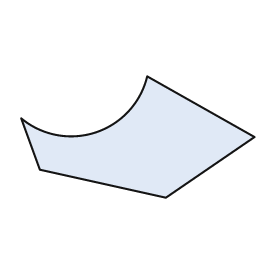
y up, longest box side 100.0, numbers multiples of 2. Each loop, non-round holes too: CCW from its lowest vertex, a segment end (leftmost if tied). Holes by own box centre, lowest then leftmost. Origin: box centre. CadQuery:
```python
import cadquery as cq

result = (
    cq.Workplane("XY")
    .moveTo(12.0, -26.0)
    .lineTo(50.0, 0.0)
    .lineTo(4.0, 26.0)
    .threePointArc((-18.0, 2.0), (-50.0, 8.0))
    .lineTo(-42.0, -14.0)
    .close()
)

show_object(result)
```